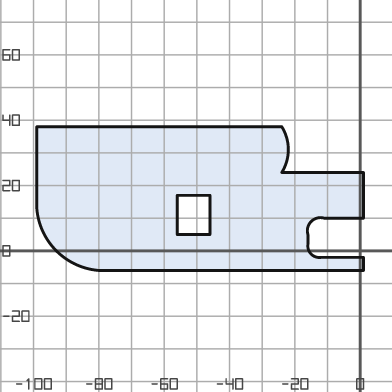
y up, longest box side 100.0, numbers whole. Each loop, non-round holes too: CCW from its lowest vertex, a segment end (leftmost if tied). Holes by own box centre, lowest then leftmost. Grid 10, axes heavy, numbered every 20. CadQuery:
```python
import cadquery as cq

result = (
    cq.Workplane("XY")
    .moveTo(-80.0, -6.0)
    .lineTo(1.0, -6.0)
    .lineTo(1.0, -2.0)
    .lineTo(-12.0, -2.0)
    .threePointArc((-15.0, -1.0), (-16.0, 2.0))
    .lineTo(-16.0, 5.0)
    .threePointArc((-15.0, 9.0), (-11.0, 10.0))
    .lineTo(1.0, 10.0)
    .lineTo(1.0, 24.0)
    .lineTo(-24.0, 24.0)
    .threePointArc((-22.0, 31.0), (-24.0, 38.0))
    .lineTo(-99.0, 38.0)
    .lineTo(-99.0, 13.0)
    .threePointArc((-93.0, 0.0), (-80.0, -6.0))
    .close()
    .moveTo(-56.0, 5.0)
    .lineTo(-46.0, 5.0)
    .lineTo(-46.0, 17.0)
    .lineTo(-56.0, 17.0)
    .close()
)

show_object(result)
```